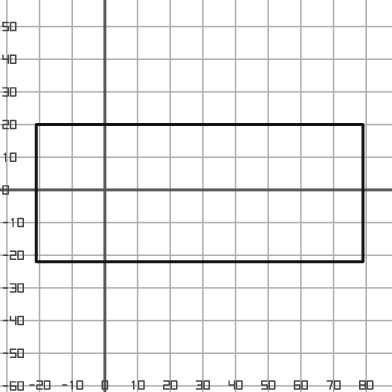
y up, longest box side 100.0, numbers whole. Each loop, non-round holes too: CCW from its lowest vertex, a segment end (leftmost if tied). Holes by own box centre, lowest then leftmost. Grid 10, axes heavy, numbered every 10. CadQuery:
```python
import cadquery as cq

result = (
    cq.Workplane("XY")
    .moveTo(-21.0, -22.0)
    .lineTo(79.0, -22.0)
    .lineTo(79.0, 20.0)
    .lineTo(-21.0, 20.0)
    .close()
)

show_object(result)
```